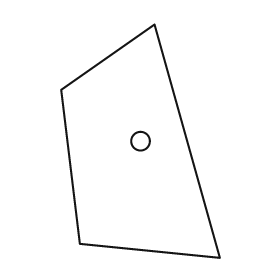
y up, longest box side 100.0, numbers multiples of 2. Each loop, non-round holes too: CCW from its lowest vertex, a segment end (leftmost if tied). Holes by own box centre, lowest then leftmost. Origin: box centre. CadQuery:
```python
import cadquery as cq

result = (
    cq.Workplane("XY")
    .moveTo(34.0, -50.0)
    .lineTo(6.0, 50.0)
    .lineTo(-34.0, 22.0)
    .lineTo(-26.0, -44.0)
    .close()
    .moveTo(0.0, 0.0)
    .circle(4.0)
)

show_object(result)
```